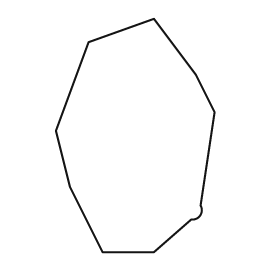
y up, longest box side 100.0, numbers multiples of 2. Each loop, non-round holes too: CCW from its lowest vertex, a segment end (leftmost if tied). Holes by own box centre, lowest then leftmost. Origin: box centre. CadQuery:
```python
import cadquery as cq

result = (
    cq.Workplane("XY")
    .moveTo(-14.0, -50.0)
    .lineTo(8.0, -50.0)
    .lineTo(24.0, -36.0)
    .threePointArc((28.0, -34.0), (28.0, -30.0))
    .lineTo(34.0, 10.0)
    .lineTo(26.0, 26.0)
    .lineTo(8.0, 50.0)
    .lineTo(-20.0, 40.0)
    .lineTo(-34.0, 2.0)
    .lineTo(-28.0, -22.0)
    .close()
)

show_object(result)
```